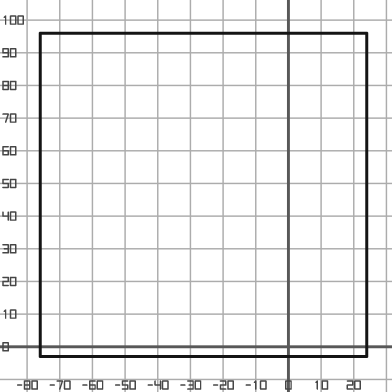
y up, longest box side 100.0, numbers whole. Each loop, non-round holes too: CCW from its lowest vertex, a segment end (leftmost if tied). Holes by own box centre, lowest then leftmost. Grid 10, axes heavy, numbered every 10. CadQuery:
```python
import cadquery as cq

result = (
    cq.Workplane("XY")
    .moveTo(-76.0, -3.0)
    .lineTo(24.0, -3.0)
    .lineTo(24.0, 96.0)
    .lineTo(-76.0, 96.0)
    .close()
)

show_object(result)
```